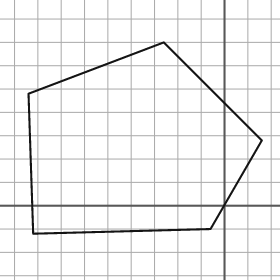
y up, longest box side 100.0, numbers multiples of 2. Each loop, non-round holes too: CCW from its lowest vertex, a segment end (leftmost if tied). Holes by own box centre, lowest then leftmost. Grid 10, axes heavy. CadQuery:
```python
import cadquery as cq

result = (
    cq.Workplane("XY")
    .moveTo(-82.0, -12.0)
    .lineTo(-6.0, -10.0)
    .lineTo(16.0, 28.0)
    .lineTo(-26.0, 70.0)
    .lineTo(-84.0, 48.0)
    .close()
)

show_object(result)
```